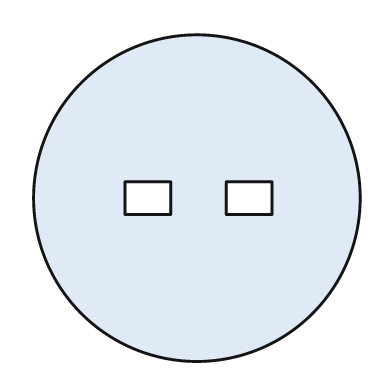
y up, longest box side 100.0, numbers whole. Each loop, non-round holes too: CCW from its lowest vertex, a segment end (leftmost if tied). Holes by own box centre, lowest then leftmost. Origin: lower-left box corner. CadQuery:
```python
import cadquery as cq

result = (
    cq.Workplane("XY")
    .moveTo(50.0, 50.0)
    .circle(50.0)
    .moveTo(28.0, 45.0)
    .lineTo(42.0, 45.0)
    .lineTo(42.0, 55.0)
    .lineTo(28.0, 55.0)
    .close()
    .moveTo(59.0, 45.0)
    .lineTo(73.0, 45.0)
    .lineTo(73.0, 55.0)
    .lineTo(59.0, 55.0)
    .close()
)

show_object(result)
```